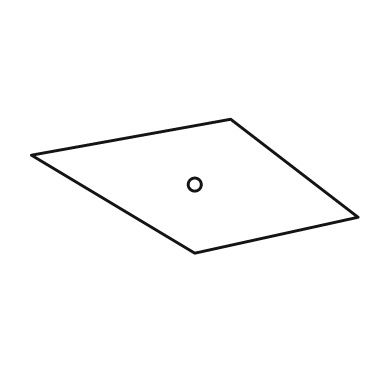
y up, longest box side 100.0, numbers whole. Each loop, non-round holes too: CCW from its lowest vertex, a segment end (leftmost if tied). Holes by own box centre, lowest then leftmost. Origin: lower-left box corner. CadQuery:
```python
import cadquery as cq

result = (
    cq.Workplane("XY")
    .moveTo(50.0, 0.0)
    .lineTo(100.0, 11.0)
    .lineTo(61.0, 41.0)
    .lineTo(0.0, 30.0)
    .close()
    .moveTo(50.0, 21.0)
    .circle(2.0)
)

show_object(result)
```